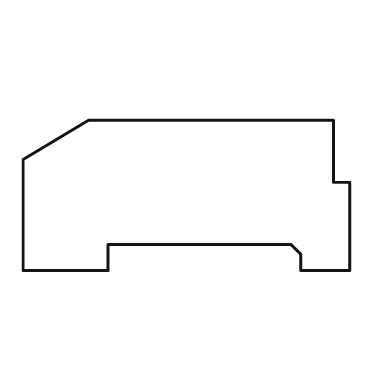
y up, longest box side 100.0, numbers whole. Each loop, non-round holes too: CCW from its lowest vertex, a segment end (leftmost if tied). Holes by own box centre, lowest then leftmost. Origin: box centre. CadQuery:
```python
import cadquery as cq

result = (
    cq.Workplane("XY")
    .moveTo(-50.0, -23.0)
    .lineTo(-24.0, -23.0)
    .lineTo(-24.0, -15.0)
    .lineTo(32.0, -15.0)
    .lineTo(35.0, -18.0)
    .lineTo(35.0, -23.0)
    .lineTo(50.0, -23.0)
    .lineTo(50.0, 4.0)
    .lineTo(45.0, 4.0)
    .lineTo(45.0, 23.0)
    .lineTo(-30.0, 23.0)
    .lineTo(-50.0, 11.0)
    .close()
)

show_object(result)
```